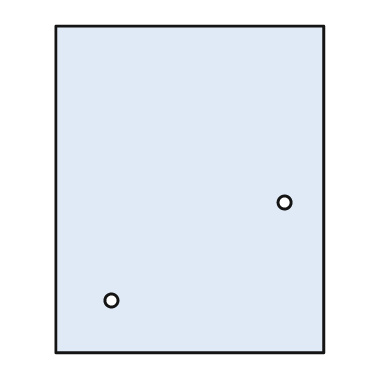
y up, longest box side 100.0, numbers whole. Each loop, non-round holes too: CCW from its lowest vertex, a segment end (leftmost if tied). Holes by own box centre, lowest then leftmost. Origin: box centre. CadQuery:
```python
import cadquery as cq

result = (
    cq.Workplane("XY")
    .moveTo(-41.0, -50.0)
    .lineTo(41.0, -50.0)
    .lineTo(41.0, 50.0)
    .lineTo(-41.0, 50.0)
    .close()
    .moveTo(-24.0, -34.0)
    .circle(2.0)
    .moveTo(29.0, -4.0)
    .circle(2.0)
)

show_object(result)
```